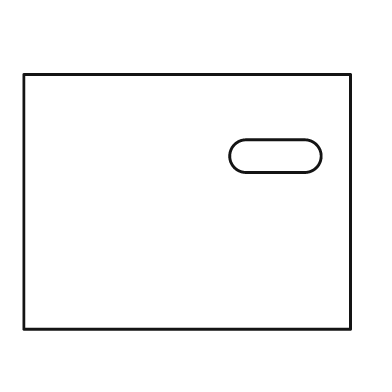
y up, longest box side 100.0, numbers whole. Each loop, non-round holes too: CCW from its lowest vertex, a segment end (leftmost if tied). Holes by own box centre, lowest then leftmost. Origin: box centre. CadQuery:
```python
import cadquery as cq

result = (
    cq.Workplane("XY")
    .moveTo(-50.0, -39.0)
    .lineTo(50.0, -39.0)
    .lineTo(50.0, 39.0)
    .lineTo(-50.0, 39.0)
    .close()
    .moveTo(18.0, 9.0)
    .lineTo(36.0, 9.0)
    .threePointArc((41.0, 14.0), (36.0, 19.0))
    .lineTo(18.0, 19.0)
    .threePointArc((13.0, 14.0), (18.0, 9.0))
    .close()
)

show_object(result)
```